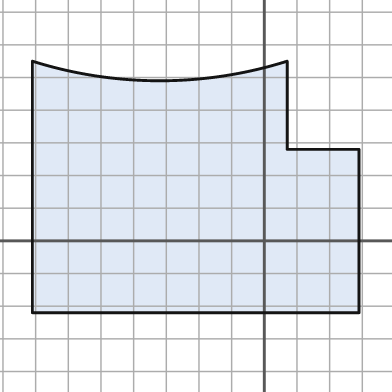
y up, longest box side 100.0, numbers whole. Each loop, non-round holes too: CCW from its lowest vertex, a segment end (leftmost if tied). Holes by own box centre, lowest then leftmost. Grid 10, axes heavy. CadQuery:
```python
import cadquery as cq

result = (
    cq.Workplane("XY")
    .moveTo(-71.0, -22.0)
    .lineTo(29.0, -22.0)
    .lineTo(29.0, 28.0)
    .lineTo(7.0, 28.0)
    .lineTo(7.0, 55.0)
    .threePointArc((-32.0, 49.0), (-71.0, 55.0))
    .close()
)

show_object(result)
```